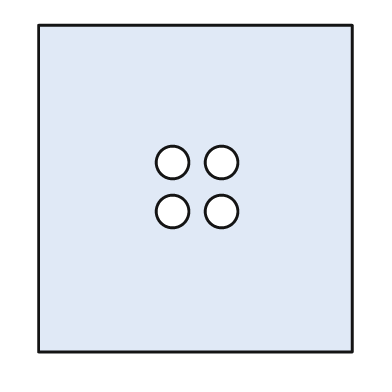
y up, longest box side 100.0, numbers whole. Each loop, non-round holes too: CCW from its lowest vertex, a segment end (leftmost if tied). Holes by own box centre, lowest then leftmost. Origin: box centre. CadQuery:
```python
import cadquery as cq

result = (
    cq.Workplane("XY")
    .moveTo(-48.0, -50.0)
    .lineTo(48.0, -50.0)
    .lineTo(48.0, 50.0)
    .lineTo(-48.0, 50.0)
    .close()
    .moveTo(-7.0, -7.0)
    .circle(5.0)
    .moveTo(8.0, -7.0)
    .circle(5.0)
    .moveTo(-7.0, 8.0)
    .circle(5.0)
    .moveTo(8.0, 8.0)
    .circle(5.0)
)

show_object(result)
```